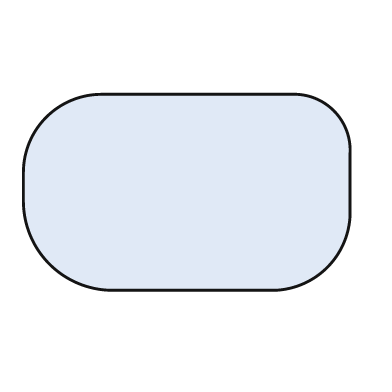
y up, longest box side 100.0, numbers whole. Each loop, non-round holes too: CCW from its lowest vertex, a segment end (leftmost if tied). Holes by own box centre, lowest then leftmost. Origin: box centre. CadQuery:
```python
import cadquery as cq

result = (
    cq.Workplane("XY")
    .moveTo(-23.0, -30.0)
    .lineTo(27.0, -30.0)
    .threePointArc((43.0, -23.0), (50.0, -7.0))
    .lineTo(50.0, 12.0)
    .threePointArc((45.0, 25.0), (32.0, 30.0))
    .lineTo(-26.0, 30.0)
    .threePointArc((-43.0, 23.0), (-50.0, 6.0))
    .lineTo(-50.0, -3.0)
    .threePointArc((-42.0, -22.0), (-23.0, -30.0))
    .close()
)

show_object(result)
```